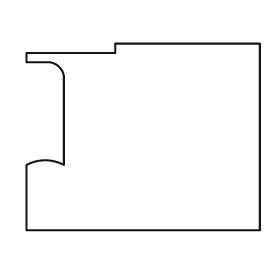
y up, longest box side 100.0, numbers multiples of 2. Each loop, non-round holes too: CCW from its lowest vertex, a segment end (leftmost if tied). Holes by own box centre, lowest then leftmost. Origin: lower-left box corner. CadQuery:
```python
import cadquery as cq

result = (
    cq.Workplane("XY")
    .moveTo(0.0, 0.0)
    .lineTo(100.0, 0.0)
    .lineTo(100.0, 80.0)
    .lineTo(38.0, 80.0)
    .lineTo(38.0, 76.0)
    .lineTo(0.0, 76.0)
    .lineTo(0.0, 72.0)
    .lineTo(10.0, 72.0)
    .threePointArc((14.0, 70.0), (16.0, 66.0))
    .lineTo(16.0, 28.0)
    .threePointArc((8.0, 30.0), (0.0, 28.0))
    .close()
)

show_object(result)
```